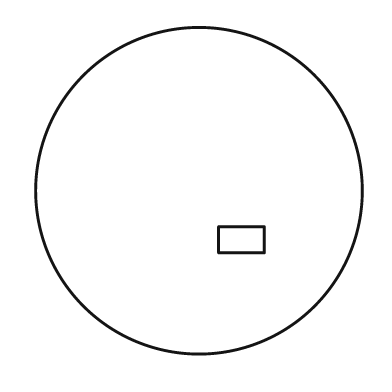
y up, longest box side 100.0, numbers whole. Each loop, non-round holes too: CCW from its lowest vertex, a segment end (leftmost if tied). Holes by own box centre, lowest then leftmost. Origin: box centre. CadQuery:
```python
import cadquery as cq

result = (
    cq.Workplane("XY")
    .moveTo(0.0, 0.0)
    .circle(50.0)
    .moveTo(6.0, -19.0)
    .lineTo(20.0, -19.0)
    .lineTo(20.0, -11.0)
    .lineTo(6.0, -11.0)
    .close()
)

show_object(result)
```